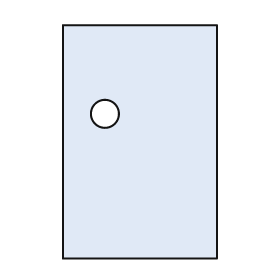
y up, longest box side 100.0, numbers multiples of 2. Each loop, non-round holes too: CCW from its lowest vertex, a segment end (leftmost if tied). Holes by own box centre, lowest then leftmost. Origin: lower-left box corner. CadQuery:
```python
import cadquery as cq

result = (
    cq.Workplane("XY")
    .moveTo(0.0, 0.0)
    .lineTo(66.0, 0.0)
    .lineTo(66.0, 100.0)
    .lineTo(0.0, 100.0)
    .close()
    .moveTo(18.0, 62.0)
    .circle(6.0)
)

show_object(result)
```